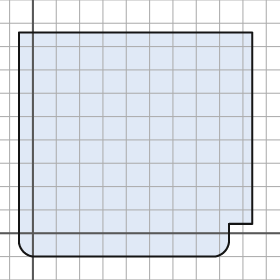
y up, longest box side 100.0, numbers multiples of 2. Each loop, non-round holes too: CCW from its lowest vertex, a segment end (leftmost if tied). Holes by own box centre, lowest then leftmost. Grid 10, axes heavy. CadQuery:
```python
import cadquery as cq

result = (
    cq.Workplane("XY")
    .moveTo(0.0, -10.0)
    .lineTo(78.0, -10.0)
    .threePointArc((82.0, -8.0), (84.0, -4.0))
    .lineTo(84.0, 4.0)
    .lineTo(94.0, 4.0)
    .lineTo(94.0, 86.0)
    .lineTo(-6.0, 86.0)
    .lineTo(-6.0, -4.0)
    .threePointArc((-4.0, -8.0), (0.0, -10.0))
    .close()
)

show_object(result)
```